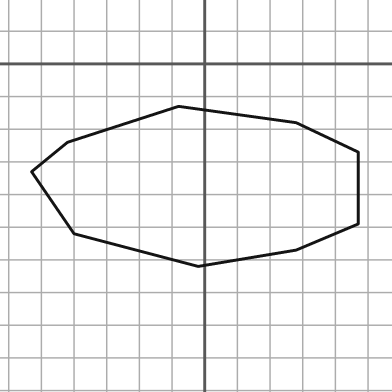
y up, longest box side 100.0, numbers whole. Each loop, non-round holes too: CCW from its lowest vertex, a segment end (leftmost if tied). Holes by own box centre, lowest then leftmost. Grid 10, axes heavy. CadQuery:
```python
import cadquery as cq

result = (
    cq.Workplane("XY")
    .moveTo(-2.0, -62.0)
    .lineTo(28.0, -57.0)
    .lineTo(47.0, -49.0)
    .lineTo(47.0, -27.0)
    .lineTo(28.0, -18.0)
    .lineTo(-8.0, -13.0)
    .lineTo(-42.0, -24.0)
    .lineTo(-53.0, -33.0)
    .lineTo(-40.0, -52.0)
    .close()
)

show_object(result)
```